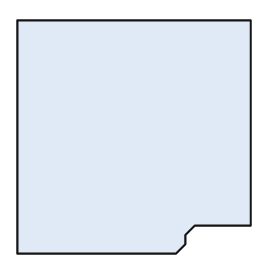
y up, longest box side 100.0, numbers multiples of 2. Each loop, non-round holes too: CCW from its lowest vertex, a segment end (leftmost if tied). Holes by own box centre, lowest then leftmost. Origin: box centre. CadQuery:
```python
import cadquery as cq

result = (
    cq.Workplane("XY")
    .moveTo(-50.0, -50.0)
    .lineTo(18.0, -50.0)
    .lineTo(22.0, -46.0)
    .lineTo(22.0, -42.0)
    .lineTo(26.0, -38.0)
    .lineTo(50.0, -38.0)
    .lineTo(50.0, 50.0)
    .lineTo(-50.0, 50.0)
    .close()
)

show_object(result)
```